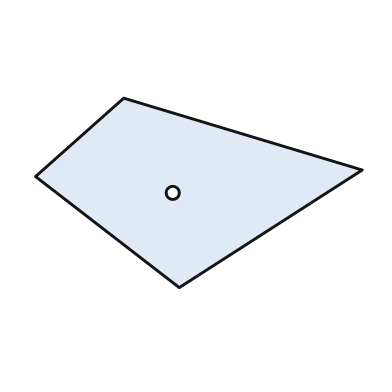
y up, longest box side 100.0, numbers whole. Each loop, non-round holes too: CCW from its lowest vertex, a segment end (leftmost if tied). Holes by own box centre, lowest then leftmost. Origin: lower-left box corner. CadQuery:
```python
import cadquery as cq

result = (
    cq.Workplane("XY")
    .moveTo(44.0, 0.0)
    .lineTo(100.0, 36.0)
    .lineTo(27.0, 58.0)
    .lineTo(0.0, 34.0)
    .close()
    .moveTo(42.0, 29.0)
    .circle(2.0)
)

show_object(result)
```